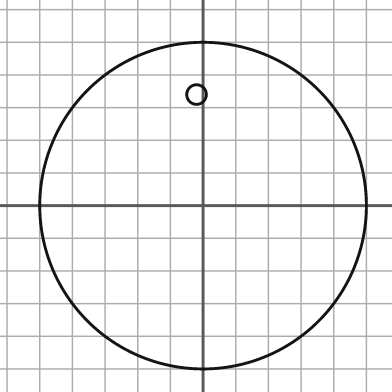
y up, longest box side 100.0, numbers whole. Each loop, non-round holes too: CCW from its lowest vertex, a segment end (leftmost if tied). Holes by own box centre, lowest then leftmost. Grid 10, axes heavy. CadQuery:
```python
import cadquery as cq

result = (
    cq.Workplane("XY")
    .moveTo(0.0, 0.0)
    .circle(50.0)
    .moveTo(-2.0, 34.0)
    .circle(3.0)
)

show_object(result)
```